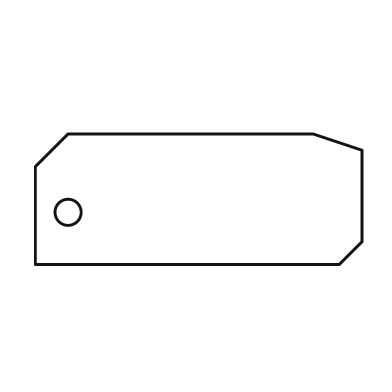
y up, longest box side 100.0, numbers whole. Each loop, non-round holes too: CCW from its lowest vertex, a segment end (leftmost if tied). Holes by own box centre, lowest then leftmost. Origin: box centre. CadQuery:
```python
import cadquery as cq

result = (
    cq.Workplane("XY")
    .moveTo(-50.0, -20.0)
    .lineTo(43.0, -20.0)
    .lineTo(50.0, -13.0)
    .lineTo(50.0, 15.0)
    .lineTo(35.0, 20.0)
    .lineTo(-40.0, 20.0)
    .lineTo(-50.0, 10.0)
    .close()
    .moveTo(-40.0, -4.0)
    .circle(4.0)
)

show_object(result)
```